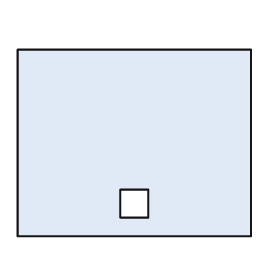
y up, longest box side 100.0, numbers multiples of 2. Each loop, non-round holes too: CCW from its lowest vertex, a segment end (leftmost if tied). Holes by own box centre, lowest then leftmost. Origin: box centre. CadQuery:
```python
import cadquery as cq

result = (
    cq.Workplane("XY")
    .moveTo(-50.0, -40.0)
    .lineTo(50.0, -40.0)
    .lineTo(50.0, 40.0)
    .lineTo(-50.0, 40.0)
    .close()
    .moveTo(-6.0, -32.0)
    .lineTo(6.0, -32.0)
    .lineTo(6.0, -20.0)
    .lineTo(-6.0, -20.0)
    .close()
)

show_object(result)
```